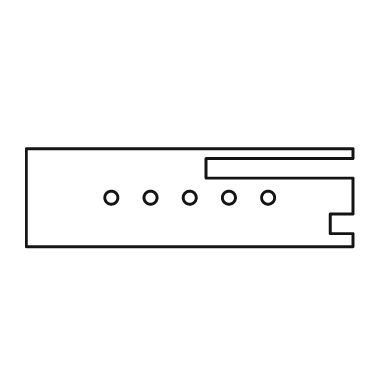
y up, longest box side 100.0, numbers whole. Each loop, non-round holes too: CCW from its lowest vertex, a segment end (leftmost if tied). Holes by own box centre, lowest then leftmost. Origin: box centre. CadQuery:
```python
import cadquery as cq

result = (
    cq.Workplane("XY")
    .moveTo(-50.0, -15.0)
    .lineTo(50.0, -15.0)
    .lineTo(50.0, -11.0)
    .lineTo(43.0, -11.0)
    .lineTo(43.0, -5.0)
    .lineTo(50.0, -5.0)
    .lineTo(50.0, 6.0)
    .lineTo(5.0, 6.0)
    .lineTo(5.0, 12.0)
    .lineTo(50.0, 12.0)
    .lineTo(50.0, 15.0)
    .lineTo(-50.0, 15.0)
    .close()
    .moveTo(-24.0, 0.0)
    .circle(2.0)
    .moveTo(-12.0, 0.0)
    .circle(2.0)
    .moveTo(0.0, 0.0)
    .circle(2.0)
    .moveTo(12.0, 0.0)
    .circle(2.0)
    .moveTo(24.0, 0.0)
    .circle(2.0)
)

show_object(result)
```